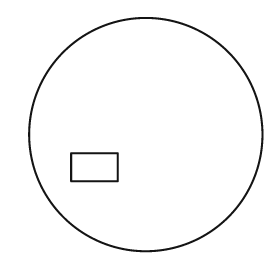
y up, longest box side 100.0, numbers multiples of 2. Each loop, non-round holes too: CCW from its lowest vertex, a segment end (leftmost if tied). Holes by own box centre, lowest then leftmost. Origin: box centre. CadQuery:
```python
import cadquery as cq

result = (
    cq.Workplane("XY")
    .moveTo(0.0, 0.0)
    .circle(50.0)
    .moveTo(-32.0, -20.0)
    .lineTo(-12.0, -20.0)
    .lineTo(-12.0, -8.0)
    .lineTo(-32.0, -8.0)
    .close()
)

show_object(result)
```